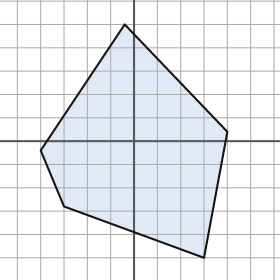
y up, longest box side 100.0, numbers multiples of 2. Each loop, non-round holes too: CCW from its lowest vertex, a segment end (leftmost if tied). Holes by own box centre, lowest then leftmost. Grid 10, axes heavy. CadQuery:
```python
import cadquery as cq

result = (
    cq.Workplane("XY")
    .moveTo(30.0, -50.0)
    .lineTo(40.0, 4.0)
    .lineTo(-4.0, 50.0)
    .lineTo(-40.0, -4.0)
    .lineTo(-30.0, -28.0)
    .close()
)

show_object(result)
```